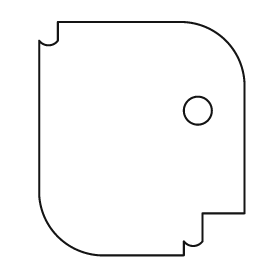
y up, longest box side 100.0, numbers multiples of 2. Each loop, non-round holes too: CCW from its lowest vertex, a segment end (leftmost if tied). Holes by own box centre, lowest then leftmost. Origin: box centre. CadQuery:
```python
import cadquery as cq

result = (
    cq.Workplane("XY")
    .moveTo(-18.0, -50.0)
    .lineTo(18.0, -50.0)
    .lineTo(18.0, -44.0)
    .threePointArc((22.0, -46.0), (26.0, -44.0))
    .lineTo(26.0, -32.0)
    .lineTo(44.0, -32.0)
    .lineTo(44.0, 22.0)
    .threePointArc((36.0, 42.0), (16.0, 50.0))
    .lineTo(-36.0, 50.0)
    .lineTo(-36.0, 42.0)
    .threePointArc((-40.0, 40.0), (-44.0, 42.0))
    .lineTo(-44.0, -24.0)
    .threePointArc((-36.0, -42.0), (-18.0, -50.0))
    .close()
    .moveTo(24.0, 12.0)
    .circle(6.0)
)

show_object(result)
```